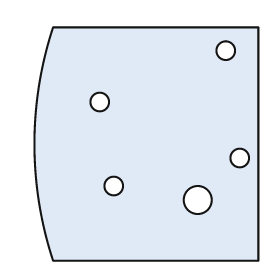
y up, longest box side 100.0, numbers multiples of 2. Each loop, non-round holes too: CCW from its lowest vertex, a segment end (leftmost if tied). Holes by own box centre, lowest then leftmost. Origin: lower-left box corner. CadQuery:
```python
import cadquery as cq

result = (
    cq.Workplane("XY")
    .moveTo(8.0, 0.0)
    .lineTo(96.0, 0.0)
    .lineTo(96.0, 100.0)
    .lineTo(8.0, 100.0)
    .threePointArc((0.0, 50.0), (8.0, 0.0))
    .close()
    .moveTo(70.0, 26.0)
    .circle(6.0)
    .moveTo(34.0, 32.0)
    .circle(4.0)
    .moveTo(88.0, 44.0)
    .circle(4.0)
    .moveTo(28.0, 68.0)
    .circle(4.0)
    .moveTo(82.0, 90.0)
    .circle(4.0)
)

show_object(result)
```